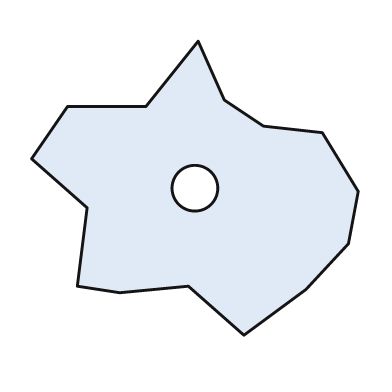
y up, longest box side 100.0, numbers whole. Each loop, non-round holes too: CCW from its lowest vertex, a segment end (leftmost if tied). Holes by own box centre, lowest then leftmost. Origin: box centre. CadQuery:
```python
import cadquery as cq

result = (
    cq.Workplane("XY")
    .moveTo(15.0, -45.0)
    .lineTo(34.0, -31.0)
    .lineTo(47.0, -17.0)
    .lineTo(50.0, -1.0)
    .lineTo(39.0, 17.0)
    .lineTo(21.0, 19.0)
    .lineTo(9.0, 27.0)
    .lineTo(1.0, 45.0)
    .lineTo(-15.0, 25.0)
    .lineTo(-39.0, 25.0)
    .lineTo(-50.0, 9.0)
    .lineTo(-33.0, -6.0)
    .lineTo(-36.0, -30.0)
    .lineTo(-23.0, -32.0)
    .lineTo(-2.0, -30.0)
    .close()
    .moveTo(0.0, 0.0)
    .circle(7.0)
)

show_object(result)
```